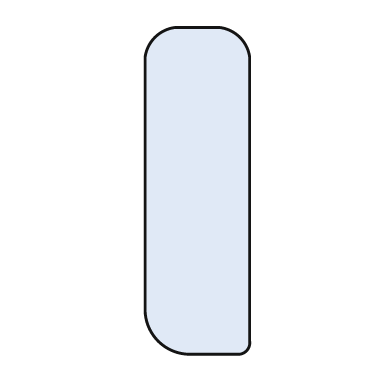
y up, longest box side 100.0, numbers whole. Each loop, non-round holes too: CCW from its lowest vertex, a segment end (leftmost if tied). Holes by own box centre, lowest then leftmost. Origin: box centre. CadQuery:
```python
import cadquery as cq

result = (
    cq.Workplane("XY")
    .moveTo(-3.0, -50.0)
    .lineTo(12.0, -50.0)
    .threePointArc((15.0, -49.0), (16.0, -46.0))
    .lineTo(16.0, 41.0)
    .threePointArc((13.0, 47.0), (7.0, 50.0))
    .lineTo(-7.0, 50.0)
    .threePointArc((-13.0, 47.0), (-16.0, 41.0))
    .lineTo(-16.0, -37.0)
    .threePointArc((-12.0, -46.0), (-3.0, -50.0))
    .close()
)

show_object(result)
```